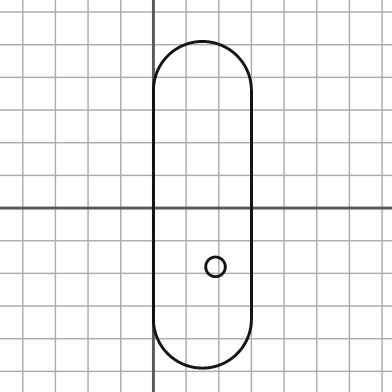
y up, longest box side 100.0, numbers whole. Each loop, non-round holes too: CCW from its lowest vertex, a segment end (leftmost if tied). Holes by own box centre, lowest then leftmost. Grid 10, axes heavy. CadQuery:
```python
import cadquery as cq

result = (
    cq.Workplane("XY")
    .moveTo(0.0, -34.0)
    .threePointArc((15.0, -49.0), (30.0, -34.0))
    .lineTo(30.0, 36.0)
    .threePointArc((15.0, 51.0), (0.0, 36.0))
    .close()
    .moveTo(19.0, -18.0)
    .circle(3.0)
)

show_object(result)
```